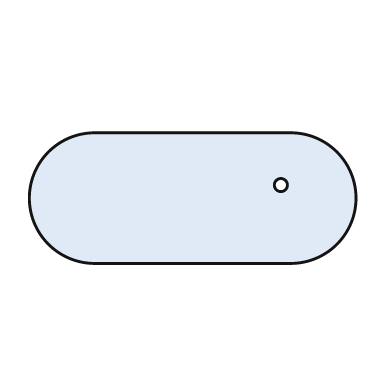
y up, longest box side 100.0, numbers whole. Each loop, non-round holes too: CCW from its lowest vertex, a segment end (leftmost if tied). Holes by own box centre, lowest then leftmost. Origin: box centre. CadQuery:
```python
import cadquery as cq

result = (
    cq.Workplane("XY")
    .moveTo(-30.0, -20.0)
    .lineTo(30.0, -20.0)
    .threePointArc((50.0, 0.0), (30.0, 20.0))
    .lineTo(-30.0, 20.0)
    .threePointArc((-50.0, 0.0), (-30.0, -20.0))
    .close()
    .moveTo(27.0, 4.0)
    .circle(2.0)
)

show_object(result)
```